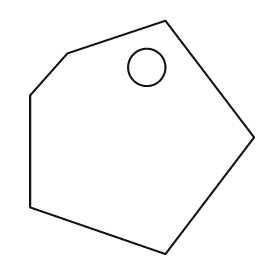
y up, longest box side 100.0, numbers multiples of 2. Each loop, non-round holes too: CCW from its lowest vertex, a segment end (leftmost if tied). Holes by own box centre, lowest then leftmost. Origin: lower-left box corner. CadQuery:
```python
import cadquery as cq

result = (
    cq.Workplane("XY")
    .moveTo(58.0, 0.0)
    .lineTo(96.0, 50.0)
    .lineTo(58.0, 100.0)
    .lineTo(16.0, 86.0)
    .lineTo(0.0, 68.0)
    .lineTo(0.0, 20.0)
    .close()
    .moveTo(50.0, 80.0)
    .circle(8.0)
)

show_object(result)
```